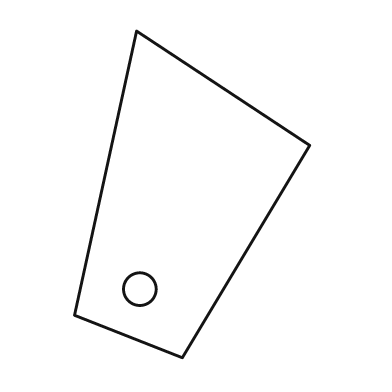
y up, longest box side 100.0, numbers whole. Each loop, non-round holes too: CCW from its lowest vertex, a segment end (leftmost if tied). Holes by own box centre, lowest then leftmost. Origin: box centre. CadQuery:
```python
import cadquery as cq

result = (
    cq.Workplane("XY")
    .moveTo(-3.0, -50.0)
    .lineTo(36.0, 15.0)
    .lineTo(-17.0, 50.0)
    .lineTo(-36.0, -37.0)
    .close()
    .moveTo(-16.0, -29.0)
    .circle(5.0)
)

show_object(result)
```